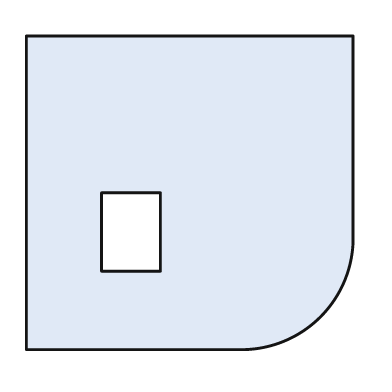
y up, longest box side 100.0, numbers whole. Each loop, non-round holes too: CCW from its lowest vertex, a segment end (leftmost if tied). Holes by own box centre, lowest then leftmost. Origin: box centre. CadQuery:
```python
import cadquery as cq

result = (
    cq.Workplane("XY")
    .moveTo(-50.0, -48.0)
    .lineTo(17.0, -48.0)
    .threePointArc((40.0, -38.0), (50.0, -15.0))
    .lineTo(50.0, 48.0)
    .lineTo(-50.0, 48.0)
    .close()
    .moveTo(-27.0, -24.0)
    .lineTo(-9.0, -24.0)
    .lineTo(-9.0, 0.0)
    .lineTo(-27.0, 0.0)
    .close()
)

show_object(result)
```